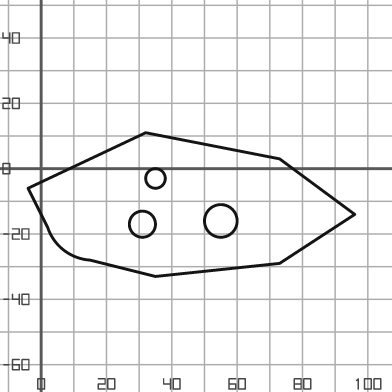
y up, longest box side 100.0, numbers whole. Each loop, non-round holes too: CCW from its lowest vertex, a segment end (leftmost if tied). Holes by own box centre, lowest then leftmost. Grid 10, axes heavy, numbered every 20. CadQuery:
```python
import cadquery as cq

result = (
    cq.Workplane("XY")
    .moveTo(35.0, -33.0)
    .lineTo(73.0, -29.0)
    .lineTo(96.0, -14.0)
    .lineTo(73.0, 3.0)
    .lineTo(32.0, 11.0)
    .lineTo(-4.0, -6.0)
    .lineTo(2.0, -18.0)
    .threePointArc((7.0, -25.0), (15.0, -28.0))
    .close()
    .moveTo(31.0, -17.0)
    .circle(4.0)
    .moveTo(55.0, -16.0)
    .circle(5.0)
    .moveTo(35.0, -3.0)
    .circle(3.0)
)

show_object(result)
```